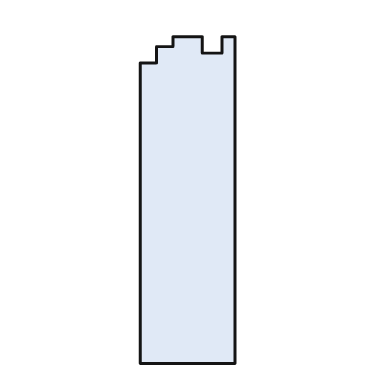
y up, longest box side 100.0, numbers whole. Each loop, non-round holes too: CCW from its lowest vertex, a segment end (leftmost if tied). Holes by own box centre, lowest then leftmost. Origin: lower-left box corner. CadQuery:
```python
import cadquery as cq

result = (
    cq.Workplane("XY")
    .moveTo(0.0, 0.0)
    .lineTo(29.0, 0.0)
    .lineTo(29.0, 100.0)
    .lineTo(25.0, 100.0)
    .lineTo(25.0, 95.0)
    .lineTo(19.0, 95.0)
    .lineTo(19.0, 100.0)
    .lineTo(10.0, 100.0)
    .lineTo(10.0, 97.0)
    .lineTo(5.0, 97.0)
    .lineTo(5.0, 92.0)
    .lineTo(0.0, 92.0)
    .close()
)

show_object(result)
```